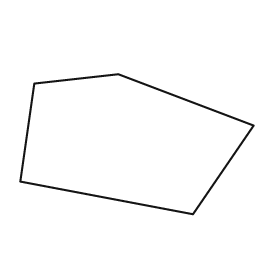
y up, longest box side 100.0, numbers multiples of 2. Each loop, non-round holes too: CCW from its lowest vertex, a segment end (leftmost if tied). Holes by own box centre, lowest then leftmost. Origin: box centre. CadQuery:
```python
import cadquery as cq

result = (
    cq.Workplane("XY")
    .moveTo(24.0, -30.0)
    .lineTo(50.0, 8.0)
    .lineTo(-8.0, 30.0)
    .lineTo(-44.0, 26.0)
    .lineTo(-50.0, -16.0)
    .close()
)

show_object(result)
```